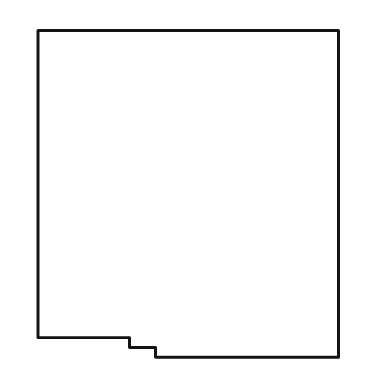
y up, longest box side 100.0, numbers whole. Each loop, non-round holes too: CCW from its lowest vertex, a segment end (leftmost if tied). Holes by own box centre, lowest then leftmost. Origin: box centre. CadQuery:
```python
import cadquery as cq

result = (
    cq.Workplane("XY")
    .moveTo(-10.0, -50.0)
    .lineTo(46.0, -50.0)
    .lineTo(46.0, 50.0)
    .lineTo(-46.0, 50.0)
    .lineTo(-46.0, -44.0)
    .lineTo(-18.0, -44.0)
    .lineTo(-18.0, -47.0)
    .lineTo(-10.0, -47.0)
    .close()
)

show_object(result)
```